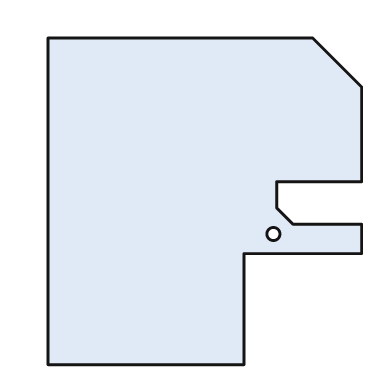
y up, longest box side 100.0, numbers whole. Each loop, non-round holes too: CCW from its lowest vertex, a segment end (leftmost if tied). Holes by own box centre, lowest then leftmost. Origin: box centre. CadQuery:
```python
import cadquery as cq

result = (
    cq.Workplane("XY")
    .moveTo(-48.0, -50.0)
    .lineTo(12.0, -50.0)
    .lineTo(12.0, -16.0)
    .lineTo(48.0, -16.0)
    .lineTo(48.0, -7.0)
    .lineTo(27.0, -7.0)
    .lineTo(22.0, -2.0)
    .lineTo(22.0, 6.0)
    .lineTo(48.0, 6.0)
    .lineTo(48.0, 35.0)
    .lineTo(33.0, 50.0)
    .lineTo(-48.0, 50.0)
    .close()
    .moveTo(21.0, -10.0)
    .circle(2.0)
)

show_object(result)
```